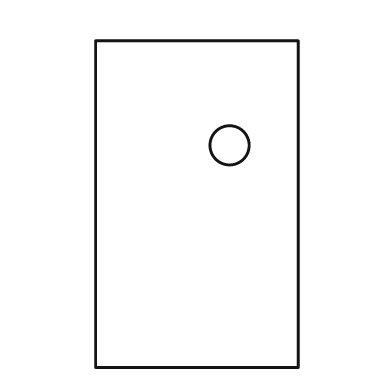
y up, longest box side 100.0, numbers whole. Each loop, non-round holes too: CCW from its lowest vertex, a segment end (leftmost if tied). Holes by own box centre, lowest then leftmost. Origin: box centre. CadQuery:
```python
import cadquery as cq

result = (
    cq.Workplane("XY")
    .moveTo(-31.0, -50.0)
    .lineTo(31.0, -50.0)
    .lineTo(31.0, 50.0)
    .lineTo(-31.0, 50.0)
    .close()
    .moveTo(10.0, 18.0)
    .circle(6.0)
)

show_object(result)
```